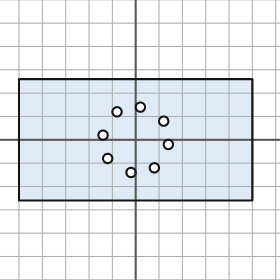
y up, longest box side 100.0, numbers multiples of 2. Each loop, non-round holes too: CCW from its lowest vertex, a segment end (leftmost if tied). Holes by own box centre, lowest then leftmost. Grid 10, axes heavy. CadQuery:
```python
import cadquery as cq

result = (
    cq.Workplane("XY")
    .moveTo(-50.0, -26.0)
    .lineTo(50.0, -26.0)
    .lineTo(50.0, 26.0)
    .lineTo(-50.0, 26.0)
    .close()
    .moveTo(-2.0, -14.0)
    .circle(2.0)
    .moveTo(8.0, -12.0)
    .circle(2.0)
    .moveTo(-12.0, -8.0)
    .circle(2.0)
    .moveTo(14.0, -2.0)
    .circle(2.0)
    .moveTo(-14.0, 2.0)
    .circle(2.0)
    .moveTo(12.0, 8.0)
    .circle(2.0)
    .moveTo(-8.0, 12.0)
    .circle(2.0)
    .moveTo(2.0, 14.0)
    .circle(2.0)
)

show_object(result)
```